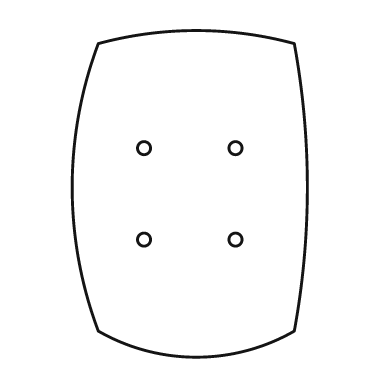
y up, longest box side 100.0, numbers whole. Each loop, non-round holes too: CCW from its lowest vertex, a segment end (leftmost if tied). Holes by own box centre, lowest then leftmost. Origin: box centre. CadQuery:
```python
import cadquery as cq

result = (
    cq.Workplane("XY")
    .moveTo(-28.0, -42.0)
    .threePointArc((2.0, -50.0), (32.0, -42.0))
    .threePointArc((36.0, 2.0), (32.0, 46.0))
    .threePointArc((2.0, 50.0), (-28.0, 46.0))
    .threePointArc((-36.0, 2.0), (-28.0, -42.0))
    .close()
    .moveTo(-14.0, -14.0)
    .circle(2.0)
    .moveTo(14.0, -14.0)
    .circle(2.0)
    .moveTo(-14.0, 14.0)
    .circle(2.0)
    .moveTo(14.0, 14.0)
    .circle(2.0)
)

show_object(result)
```